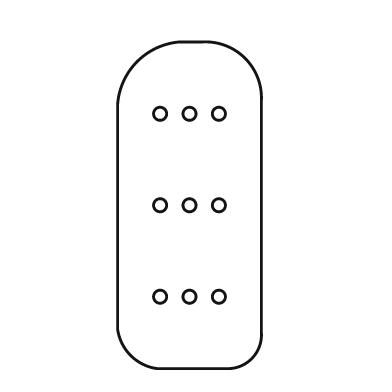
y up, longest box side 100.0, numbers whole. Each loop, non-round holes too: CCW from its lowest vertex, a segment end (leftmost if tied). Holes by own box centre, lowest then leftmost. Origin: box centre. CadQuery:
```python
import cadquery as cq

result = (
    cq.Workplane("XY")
    .moveTo(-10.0, -50.0)
    .lineTo(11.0, -50.0)
    .threePointArc((19.0, -47.0), (22.0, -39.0))
    .lineTo(22.0, 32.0)
    .threePointArc((17.0, 45.0), (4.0, 50.0))
    .lineTo(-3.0, 50.0)
    .threePointArc((-16.0, 44.0), (-22.0, 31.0))
    .lineTo(-22.0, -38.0)
    .threePointArc((-18.0, -46.0), (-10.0, -50.0))
    .close()
    .moveTo(-9.0, -28.0)
    .circle(2.0)
    .moveTo(0.0, -28.0)
    .circle(2.0)
    .moveTo(9.0, -28.0)
    .circle(2.0)
    .moveTo(-9.0, 0.0)
    .circle(2.0)
    .moveTo(0.0, 0.0)
    .circle(2.0)
    .moveTo(9.0, 0.0)
    .circle(2.0)
    .moveTo(-9.0, 28.0)
    .circle(2.0)
    .moveTo(0.0, 28.0)
    .circle(2.0)
    .moveTo(9.0, 28.0)
    .circle(2.0)
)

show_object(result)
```